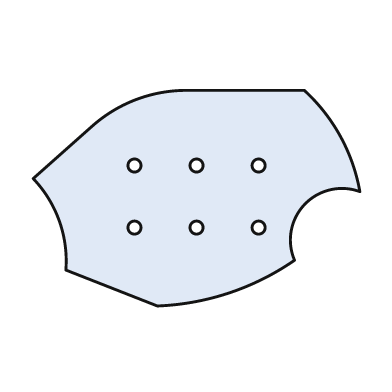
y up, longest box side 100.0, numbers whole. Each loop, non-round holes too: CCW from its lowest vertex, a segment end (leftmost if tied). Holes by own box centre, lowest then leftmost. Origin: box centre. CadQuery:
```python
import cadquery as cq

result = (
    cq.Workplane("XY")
    .moveTo(-12.0, -33.0)
    .threePointArc((10.0, -29.0), (30.0, -19.0))
    .threePointArc((33.0, -2.0), (50.0, 2.0))
    .threePointArc((44.0, 19.0), (33.0, 33.0))
    .lineTo(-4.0, 33.0)
    .threePointArc((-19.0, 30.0), (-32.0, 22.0))
    .lineTo(-50.0, 6.0)
    .threePointArc((-42.0, -7.0), (-40.0, -22.0))
    .close()
    .moveTo(-19.0, -9.0)
    .circle(2.0)
    .moveTo(0.0, -9.0)
    .circle(2.0)
    .moveTo(19.0, -9.0)
    .circle(2.0)
    .moveTo(-19.0, 10.0)
    .circle(2.0)
    .moveTo(0.0, 10.0)
    .circle(2.0)
    .moveTo(19.0, 10.0)
    .circle(2.0)
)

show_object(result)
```